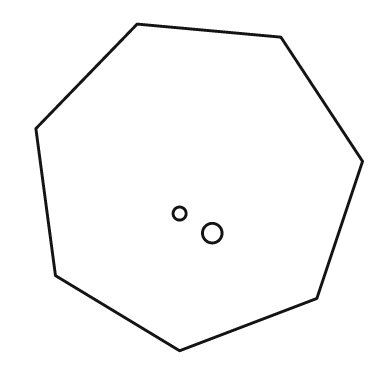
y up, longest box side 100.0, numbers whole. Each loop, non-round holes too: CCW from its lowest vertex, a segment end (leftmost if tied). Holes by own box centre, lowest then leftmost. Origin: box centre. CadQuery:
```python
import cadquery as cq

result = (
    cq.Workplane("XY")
    .moveTo(-6.0, -50.0)
    .lineTo(36.0, -34.0)
    .lineTo(50.0, 8.0)
    .lineTo(25.0, 46.0)
    .lineTo(-19.0, 50.0)
    .lineTo(-50.0, 18.0)
    .lineTo(-44.0, -27.0)
    .close()
    .moveTo(4.0, -14.0)
    .circle(3.0)
    .moveTo(-6.0, -8.0)
    .circle(2.0)
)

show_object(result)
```